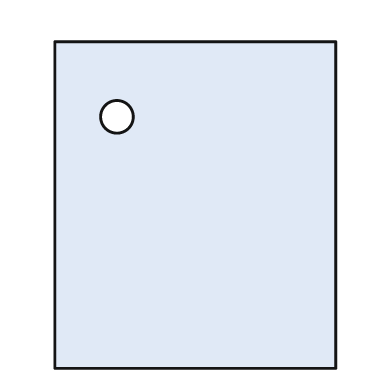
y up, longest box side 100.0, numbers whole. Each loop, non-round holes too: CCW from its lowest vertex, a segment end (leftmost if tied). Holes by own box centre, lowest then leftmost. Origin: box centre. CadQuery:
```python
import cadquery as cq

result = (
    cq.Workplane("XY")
    .moveTo(-43.0, -50.0)
    .lineTo(43.0, -50.0)
    .lineTo(43.0, 50.0)
    .lineTo(-43.0, 50.0)
    .close()
    .moveTo(-24.0, 27.0)
    .circle(5.0)
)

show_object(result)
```